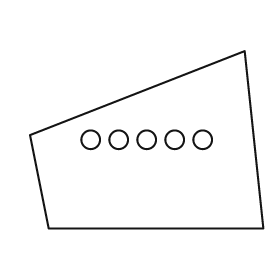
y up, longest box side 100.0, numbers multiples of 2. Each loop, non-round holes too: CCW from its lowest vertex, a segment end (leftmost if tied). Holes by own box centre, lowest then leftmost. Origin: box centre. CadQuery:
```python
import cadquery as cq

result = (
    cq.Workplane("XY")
    .moveTo(-42.0, -38.0)
    .lineTo(50.0, -38.0)
    .lineTo(42.0, 38.0)
    .lineTo(-50.0, 2.0)
    .close()
    .moveTo(-24.0, 0.0)
    .circle(4.0)
    .moveTo(-12.0, 0.0)
    .circle(4.0)
    .moveTo(0.0, 0.0)
    .circle(4.0)
    .moveTo(12.0, 0.0)
    .circle(4.0)
    .moveTo(24.0, 0.0)
    .circle(4.0)
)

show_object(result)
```